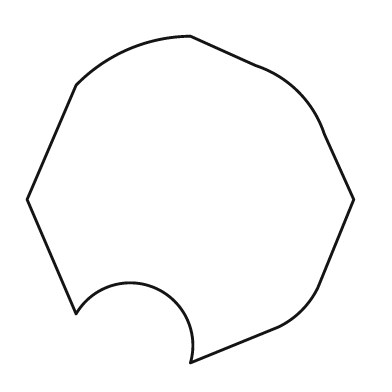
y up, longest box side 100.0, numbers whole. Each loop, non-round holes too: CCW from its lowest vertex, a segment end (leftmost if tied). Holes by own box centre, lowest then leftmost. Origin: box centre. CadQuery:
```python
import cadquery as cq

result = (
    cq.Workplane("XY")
    .moveTo(0.0, -50.0)
    .lineTo(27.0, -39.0)
    .threePointArc((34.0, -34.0), (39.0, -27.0))
    .lineTo(50.0, 0.0)
    .lineTo(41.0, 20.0)
    .threePointArc((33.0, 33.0), (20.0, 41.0))
    .lineTo(0.0, 50.0)
    .threePointArc((-19.0, 46.0), (-35.0, 35.0))
    .lineTo(-50.0, 0.0)
    .lineTo(-35.0, -35.0)
    .threePointArc((-11.0, -27.0), (0.0, -50.0))
    .close()
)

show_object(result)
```